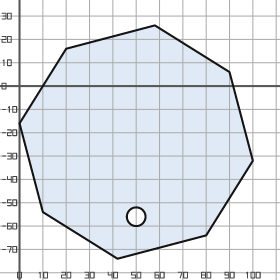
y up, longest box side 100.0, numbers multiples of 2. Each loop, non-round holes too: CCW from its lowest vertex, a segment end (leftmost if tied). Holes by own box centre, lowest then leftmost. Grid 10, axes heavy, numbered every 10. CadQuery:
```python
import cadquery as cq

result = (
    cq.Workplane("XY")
    .moveTo(42.0, -74.0)
    .lineTo(80.0, -64.0)
    .lineTo(100.0, -32.0)
    .lineTo(90.0, 6.0)
    .lineTo(58.0, 26.0)
    .lineTo(20.0, 16.0)
    .lineTo(0.0, -16.0)
    .lineTo(10.0, -54.0)
    .close()
    .moveTo(50.0, -56.0)
    .circle(4.0)
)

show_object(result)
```